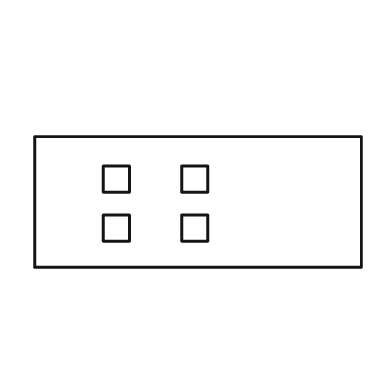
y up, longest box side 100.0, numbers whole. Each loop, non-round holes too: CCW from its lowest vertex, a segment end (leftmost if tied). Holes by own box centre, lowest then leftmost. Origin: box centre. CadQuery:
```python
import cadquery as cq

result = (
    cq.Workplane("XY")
    .moveTo(-50.0, -20.0)
    .lineTo(50.0, -20.0)
    .lineTo(50.0, 20.0)
    .lineTo(-50.0, 20.0)
    .close()
    .moveTo(-29.0, -12.0)
    .lineTo(-21.0, -12.0)
    .lineTo(-21.0, -4.0)
    .lineTo(-29.0, -4.0)
    .close()
    .moveTo(-5.0, -12.0)
    .lineTo(3.0, -12.0)
    .lineTo(3.0, -4.0)
    .lineTo(-5.0, -4.0)
    .close()
    .moveTo(-29.0, 3.0)
    .lineTo(-21.0, 3.0)
    .lineTo(-21.0, 11.0)
    .lineTo(-29.0, 11.0)
    .close()
    .moveTo(-5.0, 3.0)
    .lineTo(3.0, 3.0)
    .lineTo(3.0, 11.0)
    .lineTo(-5.0, 11.0)
    .close()
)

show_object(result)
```